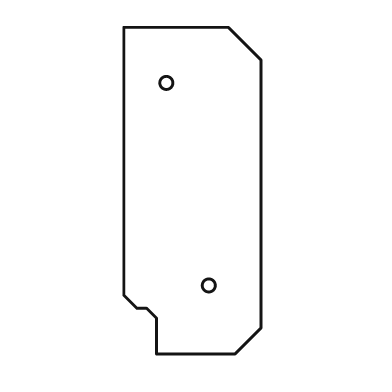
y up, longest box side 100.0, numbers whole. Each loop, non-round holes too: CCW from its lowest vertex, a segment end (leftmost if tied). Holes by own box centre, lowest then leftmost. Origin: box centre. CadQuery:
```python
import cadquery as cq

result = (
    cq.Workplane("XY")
    .moveTo(-11.0, -50.0)
    .lineTo(13.0, -50.0)
    .lineTo(21.0, -42.0)
    .lineTo(21.0, 40.0)
    .lineTo(11.0, 50.0)
    .lineTo(-21.0, 50.0)
    .lineTo(-21.0, -32.0)
    .lineTo(-17.0, -36.0)
    .lineTo(-14.0, -36.0)
    .lineTo(-11.0, -39.0)
    .close()
    .moveTo(5.0, -29.0)
    .circle(2.0)
    .moveTo(-8.0, 33.0)
    .circle(2.0)
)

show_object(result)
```